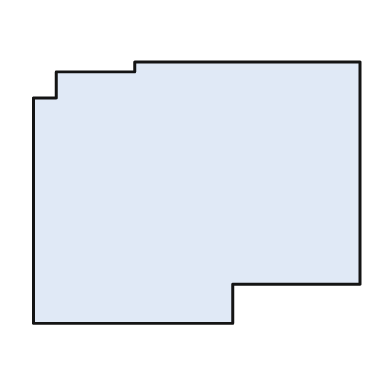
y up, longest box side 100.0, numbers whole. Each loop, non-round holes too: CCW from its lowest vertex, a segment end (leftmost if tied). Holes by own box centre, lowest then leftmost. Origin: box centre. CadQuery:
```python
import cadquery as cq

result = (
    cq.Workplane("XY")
    .moveTo(-50.0, -40.0)
    .lineTo(11.0, -40.0)
    .lineTo(11.0, -28.0)
    .lineTo(50.0, -28.0)
    .lineTo(50.0, 40.0)
    .lineTo(-19.0, 40.0)
    .lineTo(-19.0, 37.0)
    .lineTo(-43.0, 37.0)
    .lineTo(-43.0, 29.0)
    .lineTo(-50.0, 29.0)
    .close()
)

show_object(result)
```